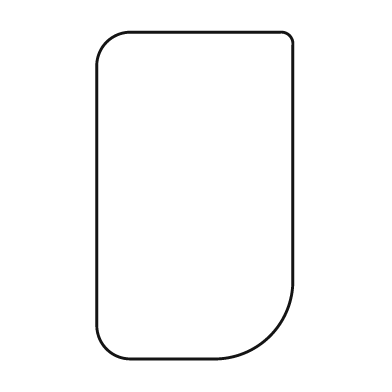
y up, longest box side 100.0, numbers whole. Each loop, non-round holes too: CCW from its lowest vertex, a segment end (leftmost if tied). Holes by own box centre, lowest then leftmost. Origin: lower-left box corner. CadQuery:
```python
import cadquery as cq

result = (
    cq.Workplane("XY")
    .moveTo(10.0, 0.0)
    .lineTo(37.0, 0.0)
    .threePointArc((53.0, 7.0), (60.0, 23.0))
    .lineTo(60.0, 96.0)
    .threePointArc((59.0, 99.0), (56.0, 100.0))
    .lineTo(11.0, 100.0)
    .threePointArc((3.0, 97.0), (0.0, 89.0))
    .lineTo(0.0, 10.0)
    .threePointArc((3.0, 3.0), (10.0, 0.0))
    .close()
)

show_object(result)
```